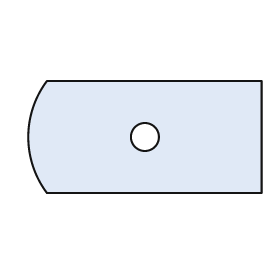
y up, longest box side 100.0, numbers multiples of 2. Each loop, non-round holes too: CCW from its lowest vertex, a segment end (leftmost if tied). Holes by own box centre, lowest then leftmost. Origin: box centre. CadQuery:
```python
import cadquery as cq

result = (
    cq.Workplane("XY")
    .moveTo(-42.0, -24.0)
    .lineTo(50.0, -24.0)
    .lineTo(50.0, 24.0)
    .lineTo(-42.0, 24.0)
    .threePointArc((-50.0, 0.0), (-42.0, -24.0))
    .close()
    .moveTo(0.0, 0.0)
    .circle(6.0)
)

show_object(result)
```